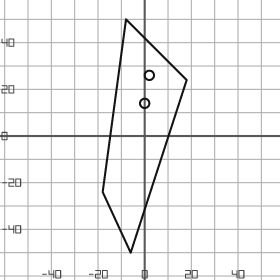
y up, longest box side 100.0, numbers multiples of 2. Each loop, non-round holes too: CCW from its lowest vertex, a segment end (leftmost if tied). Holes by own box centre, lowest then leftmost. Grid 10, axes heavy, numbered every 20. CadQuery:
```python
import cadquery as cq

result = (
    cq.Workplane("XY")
    .moveTo(-6.0, -50.0)
    .lineTo(18.0, 24.0)
    .lineTo(-8.0, 50.0)
    .lineTo(-18.0, -24.0)
    .close()
    .moveTo(0.0, 14.0)
    .circle(2.0)
    .moveTo(2.0, 26.0)
    .circle(2.0)
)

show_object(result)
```